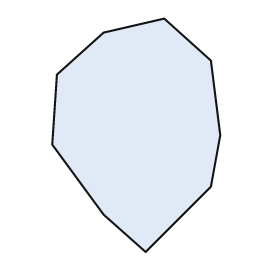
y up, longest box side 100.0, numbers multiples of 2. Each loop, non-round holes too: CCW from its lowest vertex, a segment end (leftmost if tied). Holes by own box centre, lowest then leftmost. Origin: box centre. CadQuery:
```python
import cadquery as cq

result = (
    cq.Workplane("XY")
    .moveTo(4.0, -50.0)
    .lineTo(32.0, -22.0)
    .lineTo(36.0, 0.0)
    .lineTo(32.0, 32.0)
    .lineTo(12.0, 50.0)
    .lineTo(-14.0, 44.0)
    .lineTo(-34.0, 26.0)
    .lineTo(-36.0, -4.0)
    .lineTo(-14.0, -34.0)
    .close()
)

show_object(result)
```